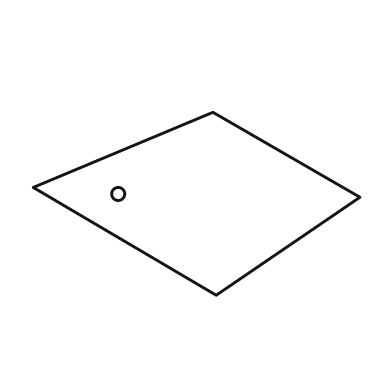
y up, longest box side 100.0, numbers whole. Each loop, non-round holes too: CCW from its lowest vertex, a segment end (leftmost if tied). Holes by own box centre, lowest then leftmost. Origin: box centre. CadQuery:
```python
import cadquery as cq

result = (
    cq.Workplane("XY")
    .moveTo(6.0, -28.0)
    .lineTo(50.0, 2.0)
    .lineTo(5.0, 28.0)
    .lineTo(-50.0, 5.0)
    .close()
    .moveTo(-24.0, 3.0)
    .circle(2.0)
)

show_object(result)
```